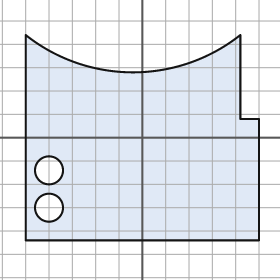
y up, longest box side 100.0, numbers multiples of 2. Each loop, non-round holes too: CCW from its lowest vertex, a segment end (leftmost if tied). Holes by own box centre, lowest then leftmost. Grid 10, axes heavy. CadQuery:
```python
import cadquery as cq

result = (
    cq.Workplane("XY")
    .moveTo(-50.0, -44.0)
    .lineTo(50.0, -44.0)
    .lineTo(50.0, 8.0)
    .lineTo(42.0, 8.0)
    .lineTo(42.0, 44.0)
    .threePointArc((-4.0, 28.0), (-50.0, 44.0))
    .close()
    .moveTo(-40.0, -30.0)
    .circle(6.0)
    .moveTo(-40.0, -14.0)
    .circle(6.0)
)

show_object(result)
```